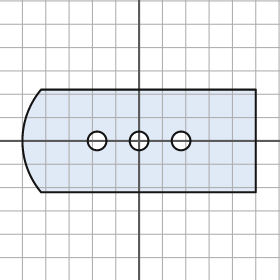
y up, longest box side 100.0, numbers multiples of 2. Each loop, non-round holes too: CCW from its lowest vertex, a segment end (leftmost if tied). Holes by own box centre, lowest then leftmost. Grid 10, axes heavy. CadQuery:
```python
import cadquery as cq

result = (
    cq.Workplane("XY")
    .moveTo(-42.0, -22.0)
    .lineTo(50.0, -22.0)
    .lineTo(50.0, 22.0)
    .lineTo(-42.0, 22.0)
    .threePointArc((-50.0, 0.0), (-42.0, -22.0))
    .close()
    .moveTo(-18.0, 0.0)
    .circle(4.0)
    .moveTo(0.0, 0.0)
    .circle(4.0)
    .moveTo(18.0, 0.0)
    .circle(4.0)
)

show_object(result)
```